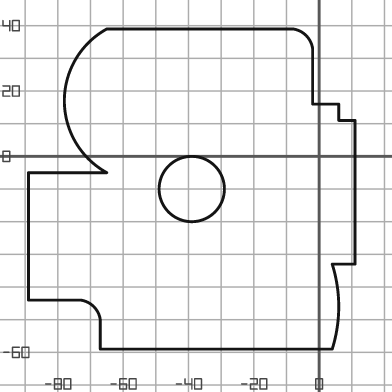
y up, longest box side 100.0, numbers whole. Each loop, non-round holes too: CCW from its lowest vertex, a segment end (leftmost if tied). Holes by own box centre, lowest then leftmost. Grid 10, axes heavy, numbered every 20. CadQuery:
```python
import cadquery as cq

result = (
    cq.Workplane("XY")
    .moveTo(-67.0, -59.0)
    .lineTo(4.0, -59.0)
    .threePointArc((6.0, -46.0), (4.0, -33.0))
    .lineTo(11.0, -33.0)
    .lineTo(11.0, 11.0)
    .lineTo(6.0, 11.0)
    .lineTo(6.0, 16.0)
    .lineTo(-2.0, 16.0)
    .lineTo(-2.0, 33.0)
    .threePointArc((-4.0, 37.0), (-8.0, 39.0))
    .lineTo(-65.0, 39.0)
    .threePointArc((-78.0, 17.0), (-65.0, -5.0))
    .lineTo(-89.0, -5.0)
    .lineTo(-89.0, -44.0)
    .lineTo(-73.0, -44.0)
    .threePointArc((-69.0, -46.0), (-67.0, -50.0))
    .close()
    .moveTo(-39.0, -10.0)
    .circle(10.0)
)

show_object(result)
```